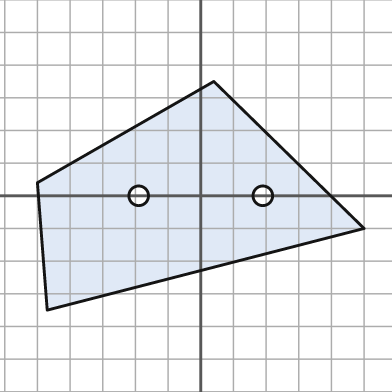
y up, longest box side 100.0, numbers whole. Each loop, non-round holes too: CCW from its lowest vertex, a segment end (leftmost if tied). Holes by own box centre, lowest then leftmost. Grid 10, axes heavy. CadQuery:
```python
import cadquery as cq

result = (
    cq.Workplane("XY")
    .moveTo(-47.0, -35.0)
    .lineTo(50.0, -10.0)
    .lineTo(4.0, 35.0)
    .lineTo(-50.0, 4.0)
    .close()
    .moveTo(-19.0, 0.0)
    .circle(3.0)
    .moveTo(19.0, 0.0)
    .circle(3.0)
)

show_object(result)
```